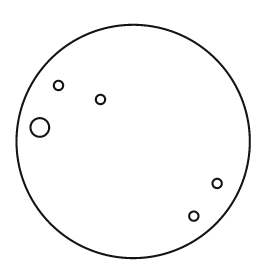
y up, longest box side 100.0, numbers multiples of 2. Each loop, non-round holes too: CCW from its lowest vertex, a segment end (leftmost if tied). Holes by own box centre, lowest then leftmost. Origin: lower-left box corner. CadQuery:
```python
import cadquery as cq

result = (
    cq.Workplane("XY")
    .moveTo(50.0, 50.0)
    .circle(50.0)
    .moveTo(76.0, 18.0)
    .circle(2.0)
    .moveTo(86.0, 32.0)
    .circle(2.0)
    .moveTo(10.0, 56.0)
    .circle(4.0)
    .moveTo(36.0, 68.0)
    .circle(2.0)
    .moveTo(18.0, 74.0)
    .circle(2.0)
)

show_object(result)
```